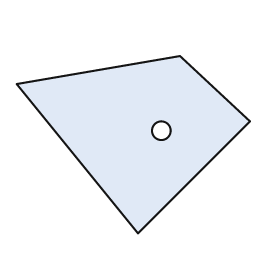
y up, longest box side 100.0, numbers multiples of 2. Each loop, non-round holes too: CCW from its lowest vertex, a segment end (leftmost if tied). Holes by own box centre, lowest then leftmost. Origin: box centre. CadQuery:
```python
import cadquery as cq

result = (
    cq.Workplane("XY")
    .moveTo(2.0, -38.0)
    .lineTo(50.0, 10.0)
    .lineTo(20.0, 38.0)
    .lineTo(-50.0, 26.0)
    .close()
    .moveTo(12.0, 6.0)
    .circle(4.0)
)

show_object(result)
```